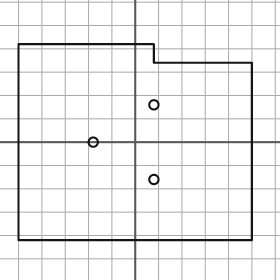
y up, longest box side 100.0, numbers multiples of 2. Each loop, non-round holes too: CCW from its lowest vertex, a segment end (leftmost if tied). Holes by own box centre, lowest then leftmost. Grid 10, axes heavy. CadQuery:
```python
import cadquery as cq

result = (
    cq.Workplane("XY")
    .moveTo(-50.0, -42.0)
    .lineTo(50.0, -42.0)
    .lineTo(50.0, 34.0)
    .lineTo(8.0, 34.0)
    .lineTo(8.0, 42.0)
    .lineTo(-50.0, 42.0)
    .close()
    .moveTo(8.0, -16.0)
    .circle(2.0)
    .moveTo(-18.0, 0.0)
    .circle(2.0)
    .moveTo(8.0, 16.0)
    .circle(2.0)
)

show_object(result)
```